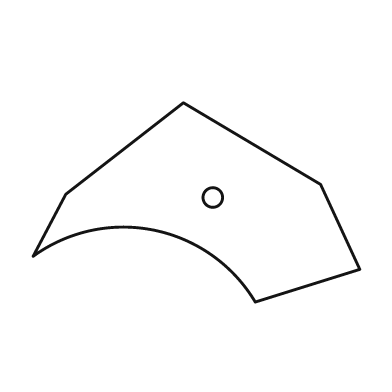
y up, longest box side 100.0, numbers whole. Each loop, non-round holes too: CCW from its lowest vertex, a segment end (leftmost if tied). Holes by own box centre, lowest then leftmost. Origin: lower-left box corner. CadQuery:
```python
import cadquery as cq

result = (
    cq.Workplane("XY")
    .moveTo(68.0, 0.0)
    .lineTo(100.0, 10.0)
    .lineTo(88.0, 36.0)
    .lineTo(46.0, 61.0)
    .lineTo(10.0, 33.0)
    .lineTo(0.0, 14.0)
    .threePointArc((37.0, 22.0), (68.0, 0.0))
    .close()
    .moveTo(55.0, 32.0)
    .circle(3.0)
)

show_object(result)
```